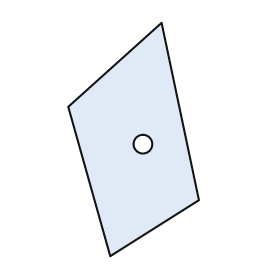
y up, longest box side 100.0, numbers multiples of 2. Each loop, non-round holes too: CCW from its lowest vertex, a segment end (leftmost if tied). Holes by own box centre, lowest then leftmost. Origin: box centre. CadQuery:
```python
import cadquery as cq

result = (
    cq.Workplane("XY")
    .moveTo(-10.0, -50.0)
    .lineTo(28.0, -26.0)
    .lineTo(12.0, 50.0)
    .lineTo(-28.0, 14.0)
    .close()
    .moveTo(4.0, -2.0)
    .circle(4.0)
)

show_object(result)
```